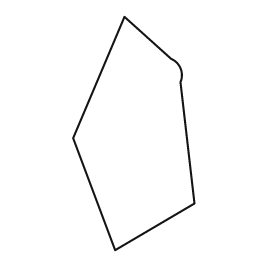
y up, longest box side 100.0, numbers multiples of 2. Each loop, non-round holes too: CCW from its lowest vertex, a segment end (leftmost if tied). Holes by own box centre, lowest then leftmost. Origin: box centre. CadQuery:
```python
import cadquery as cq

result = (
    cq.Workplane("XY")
    .moveTo(-8.0, -50.0)
    .lineTo(26.0, -30.0)
    .lineTo(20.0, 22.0)
    .threePointArc((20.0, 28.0), (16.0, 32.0))
    .lineTo(-4.0, 50.0)
    .lineTo(-26.0, -2.0)
    .close()
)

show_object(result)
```